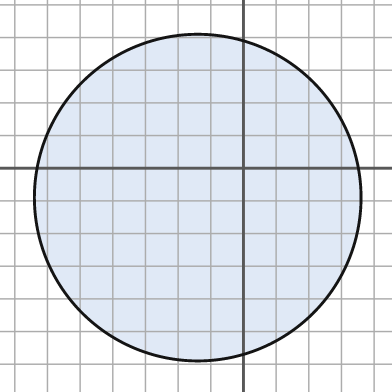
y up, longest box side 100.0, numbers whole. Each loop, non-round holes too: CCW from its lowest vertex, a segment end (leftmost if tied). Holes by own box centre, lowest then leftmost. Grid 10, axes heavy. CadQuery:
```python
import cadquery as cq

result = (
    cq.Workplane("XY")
    .moveTo(-14.0, -9.0)
    .circle(50.0)
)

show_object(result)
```